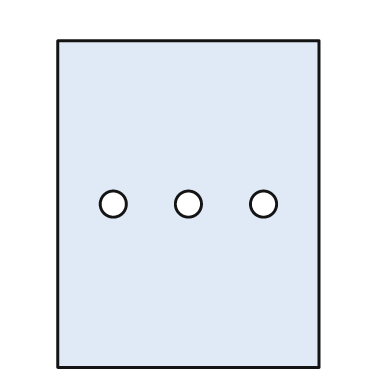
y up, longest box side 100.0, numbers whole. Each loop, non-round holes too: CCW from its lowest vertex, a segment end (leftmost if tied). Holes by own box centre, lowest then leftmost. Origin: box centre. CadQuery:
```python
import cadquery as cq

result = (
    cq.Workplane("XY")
    .moveTo(-40.0, -50.0)
    .lineTo(40.0, -50.0)
    .lineTo(40.0, 50.0)
    .lineTo(-40.0, 50.0)
    .close()
    .moveTo(-23.0, 0.0)
    .circle(4.0)
    .moveTo(0.0, 0.0)
    .circle(4.0)
    .moveTo(23.0, 0.0)
    .circle(4.0)
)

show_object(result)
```